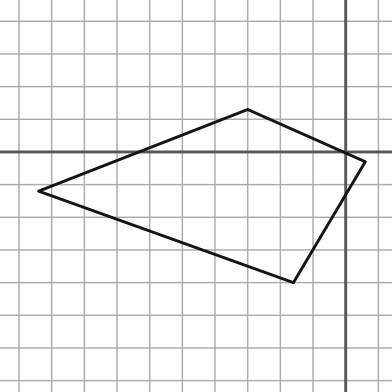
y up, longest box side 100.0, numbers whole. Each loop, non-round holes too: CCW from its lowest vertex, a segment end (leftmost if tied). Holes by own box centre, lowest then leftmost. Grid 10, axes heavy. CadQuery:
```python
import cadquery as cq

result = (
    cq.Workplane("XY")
    .moveTo(-16.0, -40.0)
    .lineTo(6.0, -3.0)
    .lineTo(-30.0, 13.0)
    .lineTo(-94.0, -12.0)
    .close()
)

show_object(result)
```